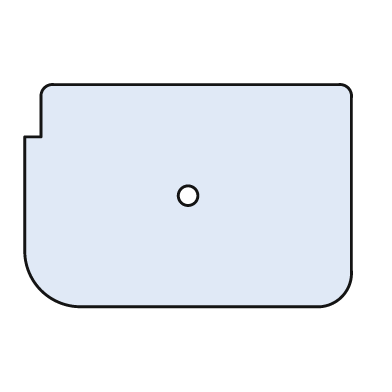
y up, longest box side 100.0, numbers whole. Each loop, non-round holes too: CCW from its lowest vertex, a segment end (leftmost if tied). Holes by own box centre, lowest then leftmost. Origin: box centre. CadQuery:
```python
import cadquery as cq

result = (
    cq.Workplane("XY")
    .moveTo(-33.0, -34.0)
    .lineTo(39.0, -34.0)
    .threePointArc((47.0, -31.0), (50.0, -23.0))
    .lineTo(50.0, 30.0)
    .threePointArc((49.0, 33.0), (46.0, 34.0))
    .lineTo(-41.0, 34.0)
    .threePointArc((-44.0, 33.0), (-45.0, 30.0))
    .lineTo(-45.0, 18.0)
    .lineTo(-50.0, 18.0)
    .lineTo(-50.0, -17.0)
    .threePointArc((-45.0, -29.0), (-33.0, -34.0))
    .close()
    .moveTo(0.0, 0.0)
    .circle(3.0)
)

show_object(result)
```